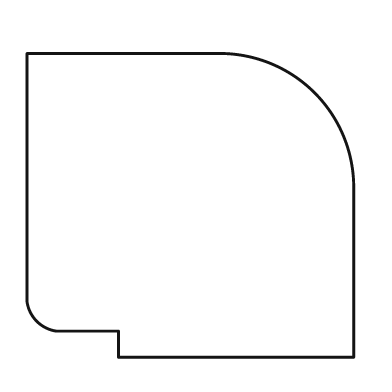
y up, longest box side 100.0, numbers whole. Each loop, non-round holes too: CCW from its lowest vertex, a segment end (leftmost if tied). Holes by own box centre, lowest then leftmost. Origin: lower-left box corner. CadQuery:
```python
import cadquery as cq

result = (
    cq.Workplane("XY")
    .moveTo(28.0, 0.0)
    .lineTo(100.0, 0.0)
    .lineTo(100.0, 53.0)
    .threePointArc((88.0, 81.0), (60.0, 93.0))
    .lineTo(0.0, 93.0)
    .lineTo(0.0, 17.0)
    .threePointArc((3.0, 11.0), (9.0, 8.0))
    .lineTo(28.0, 8.0)
    .close()
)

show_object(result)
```